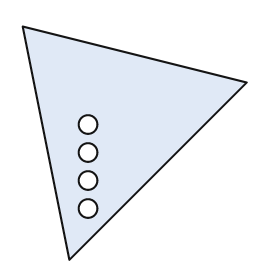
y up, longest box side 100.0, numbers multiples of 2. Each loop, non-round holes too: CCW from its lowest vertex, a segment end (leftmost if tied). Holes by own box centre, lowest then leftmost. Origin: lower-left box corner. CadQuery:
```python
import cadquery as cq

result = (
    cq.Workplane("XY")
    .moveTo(20.0, 0.0)
    .lineTo(96.0, 76.0)
    .lineTo(0.0, 100.0)
    .close()
    .moveTo(28.0, 22.0)
    .circle(4.0)
    .moveTo(28.0, 34.0)
    .circle(4.0)
    .moveTo(28.0, 46.0)
    .circle(4.0)
    .moveTo(28.0, 58.0)
    .circle(4.0)
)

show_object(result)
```